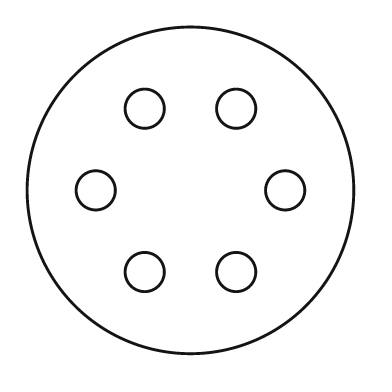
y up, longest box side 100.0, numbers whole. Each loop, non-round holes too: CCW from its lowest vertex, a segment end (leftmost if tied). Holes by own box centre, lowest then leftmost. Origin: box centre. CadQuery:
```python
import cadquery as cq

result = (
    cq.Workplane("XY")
    .moveTo(0.0, 0.0)
    .circle(50.0)
    .moveTo(-14.0, -25.0)
    .circle(6.0)
    .moveTo(14.0, -25.0)
    .circle(6.0)
    .moveTo(-29.0, 0.0)
    .circle(6.0)
    .moveTo(29.0, 0.0)
    .circle(6.0)
    .moveTo(-14.0, 25.0)
    .circle(6.0)
    .moveTo(14.0, 25.0)
    .circle(6.0)
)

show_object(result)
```